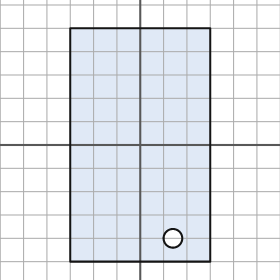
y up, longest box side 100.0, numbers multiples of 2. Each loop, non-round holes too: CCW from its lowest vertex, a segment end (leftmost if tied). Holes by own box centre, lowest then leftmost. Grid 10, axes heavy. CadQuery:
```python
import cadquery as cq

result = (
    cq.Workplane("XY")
    .moveTo(-30.0, -50.0)
    .lineTo(30.0, -50.0)
    .lineTo(30.0, 50.0)
    .lineTo(-30.0, 50.0)
    .close()
    .moveTo(14.0, -40.0)
    .circle(4.0)
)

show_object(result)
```